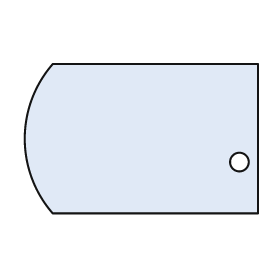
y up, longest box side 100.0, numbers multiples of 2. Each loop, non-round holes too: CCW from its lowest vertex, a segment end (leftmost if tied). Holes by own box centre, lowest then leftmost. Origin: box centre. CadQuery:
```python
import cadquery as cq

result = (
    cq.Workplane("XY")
    .moveTo(-38.0, -32.0)
    .lineTo(50.0, -32.0)
    .lineTo(50.0, 32.0)
    .lineTo(-38.0, 32.0)
    .threePointArc((-50.0, 0.0), (-38.0, -32.0))
    .close()
    .moveTo(42.0, -10.0)
    .circle(4.0)
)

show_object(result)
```